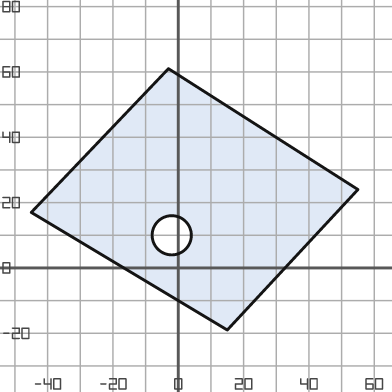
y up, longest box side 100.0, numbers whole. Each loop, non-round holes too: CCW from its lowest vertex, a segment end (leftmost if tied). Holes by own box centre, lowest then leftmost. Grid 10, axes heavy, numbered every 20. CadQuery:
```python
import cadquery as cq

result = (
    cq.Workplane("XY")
    .moveTo(15.0, -19.0)
    .lineTo(55.0, 24.0)
    .lineTo(-3.0, 61.0)
    .lineTo(-45.0, 17.0)
    .close()
    .moveTo(-2.0, 10.0)
    .circle(6.0)
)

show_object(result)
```